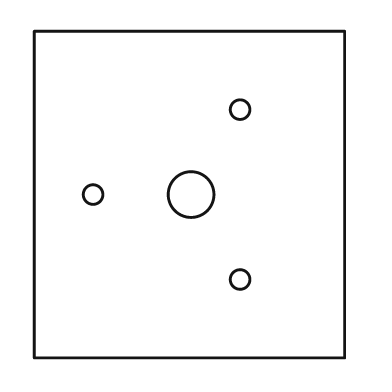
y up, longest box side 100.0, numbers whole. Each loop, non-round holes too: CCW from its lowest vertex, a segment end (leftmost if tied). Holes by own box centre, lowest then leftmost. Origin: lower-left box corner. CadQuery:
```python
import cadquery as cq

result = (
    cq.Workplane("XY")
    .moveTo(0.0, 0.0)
    .lineTo(95.0, 0.0)
    .lineTo(95.0, 100.0)
    .lineTo(0.0, 100.0)
    .close()
    .moveTo(63.0, 24.0)
    .circle(3.0)
    .moveTo(18.0, 50.0)
    .circle(3.0)
    .moveTo(48.0, 50.0)
    .circle(7.0)
    .moveTo(63.0, 76.0)
    .circle(3.0)
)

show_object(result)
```